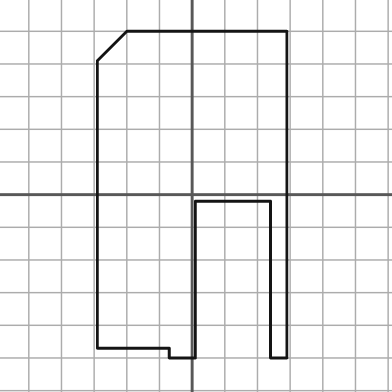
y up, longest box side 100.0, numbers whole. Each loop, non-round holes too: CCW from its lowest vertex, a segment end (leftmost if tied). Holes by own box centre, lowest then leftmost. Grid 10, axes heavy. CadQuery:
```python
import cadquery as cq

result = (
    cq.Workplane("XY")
    .moveTo(-7.0, -50.0)
    .lineTo(1.0, -50.0)
    .lineTo(1.0, -2.0)
    .lineTo(24.0, -2.0)
    .lineTo(24.0, -50.0)
    .lineTo(29.0, -50.0)
    .lineTo(29.0, 50.0)
    .lineTo(-20.0, 50.0)
    .lineTo(-29.0, 41.0)
    .lineTo(-29.0, -47.0)
    .lineTo(-7.0, -47.0)
    .close()
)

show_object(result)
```